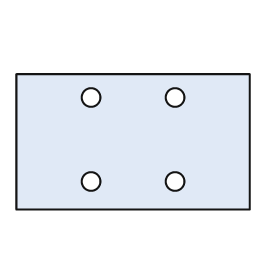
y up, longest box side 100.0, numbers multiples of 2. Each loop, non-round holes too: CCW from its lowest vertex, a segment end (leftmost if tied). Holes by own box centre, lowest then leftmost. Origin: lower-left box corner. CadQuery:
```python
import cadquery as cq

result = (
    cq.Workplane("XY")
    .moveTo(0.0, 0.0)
    .lineTo(100.0, 0.0)
    .lineTo(100.0, 58.0)
    .lineTo(0.0, 58.0)
    .close()
    .moveTo(32.0, 12.0)
    .circle(4.0)
    .moveTo(68.0, 12.0)
    .circle(4.0)
    .moveTo(32.0, 48.0)
    .circle(4.0)
    .moveTo(68.0, 48.0)
    .circle(4.0)
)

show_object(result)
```